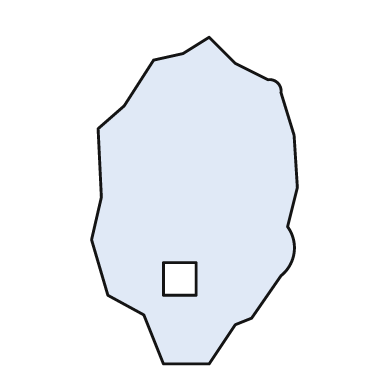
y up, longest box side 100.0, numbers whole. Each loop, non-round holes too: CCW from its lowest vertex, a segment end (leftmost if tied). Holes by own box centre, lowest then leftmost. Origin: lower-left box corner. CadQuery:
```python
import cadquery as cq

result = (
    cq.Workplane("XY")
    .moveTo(22.0, 0.0)
    .lineTo(36.0, 0.0)
    .lineTo(44.0, 12.0)
    .lineTo(49.0, 14.0)
    .lineTo(58.0, 27.0)
    .threePointArc((62.0, 34.0), (60.0, 42.0))
    .lineTo(63.0, 54.0)
    .lineTo(62.0, 70.0)
    .lineTo(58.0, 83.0)
    .threePointArc((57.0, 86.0), (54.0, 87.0))
    .lineTo(44.0, 92.0)
    .lineTo(36.0, 100.0)
    .lineTo(28.0, 95.0)
    .lineTo(19.0, 93.0)
    .lineTo(10.0, 79.0)
    .lineTo(2.0, 72.0)
    .lineTo(3.0, 51.0)
    .lineTo(0.0, 38.0)
    .lineTo(5.0, 21.0)
    .lineTo(16.0, 15.0)
    .close()
    .moveTo(22.0, 21.0)
    .lineTo(32.0, 21.0)
    .lineTo(32.0, 31.0)
    .lineTo(22.0, 31.0)
    .close()
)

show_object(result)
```